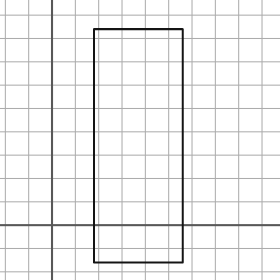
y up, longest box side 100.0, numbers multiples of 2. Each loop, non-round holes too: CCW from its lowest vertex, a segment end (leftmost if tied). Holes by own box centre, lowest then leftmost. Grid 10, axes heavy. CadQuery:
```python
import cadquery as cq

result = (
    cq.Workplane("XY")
    .moveTo(18.0, -16.0)
    .lineTo(56.0, -16.0)
    .lineTo(56.0, 84.0)
    .lineTo(18.0, 84.0)
    .close()
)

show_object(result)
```